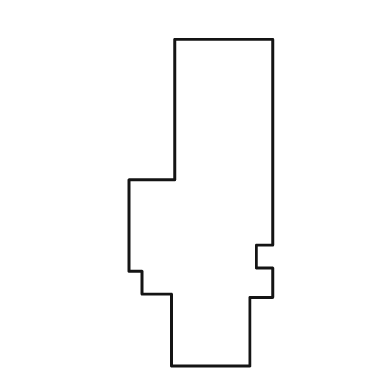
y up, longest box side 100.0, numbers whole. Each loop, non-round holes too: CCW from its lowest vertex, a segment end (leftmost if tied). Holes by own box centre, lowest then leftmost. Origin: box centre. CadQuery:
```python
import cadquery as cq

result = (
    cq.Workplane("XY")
    .moveTo(-9.0, -50.0)
    .lineTo(15.0, -50.0)
    .lineTo(15.0, -29.0)
    .lineTo(22.0, -29.0)
    .lineTo(22.0, -20.0)
    .lineTo(17.0, -20.0)
    .lineTo(17.0, -13.0)
    .lineTo(22.0, -13.0)
    .lineTo(22.0, 50.0)
    .lineTo(-8.0, 50.0)
    .lineTo(-8.0, 7.0)
    .lineTo(-22.0, 7.0)
    .lineTo(-22.0, -21.0)
    .lineTo(-18.0, -21.0)
    .lineTo(-18.0, -28.0)
    .lineTo(-9.0, -28.0)
    .close()
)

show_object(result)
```